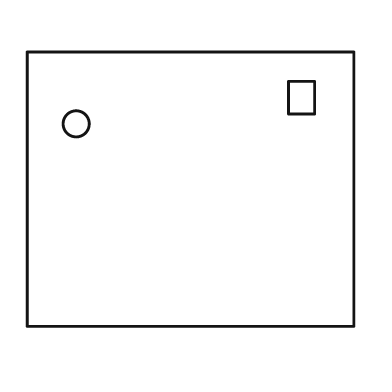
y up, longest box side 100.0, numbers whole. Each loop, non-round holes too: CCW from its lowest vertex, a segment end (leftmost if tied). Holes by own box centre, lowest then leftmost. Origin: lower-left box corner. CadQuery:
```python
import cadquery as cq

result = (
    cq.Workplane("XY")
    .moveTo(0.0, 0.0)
    .lineTo(100.0, 0.0)
    .lineTo(100.0, 84.0)
    .lineTo(0.0, 84.0)
    .close()
    .moveTo(15.0, 62.0)
    .circle(4.0)
    .moveTo(80.0, 65.0)
    .lineTo(88.0, 65.0)
    .lineTo(88.0, 75.0)
    .lineTo(80.0, 75.0)
    .close()
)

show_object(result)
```